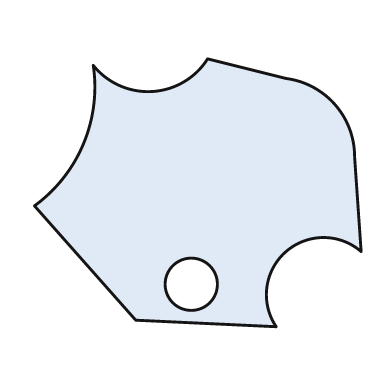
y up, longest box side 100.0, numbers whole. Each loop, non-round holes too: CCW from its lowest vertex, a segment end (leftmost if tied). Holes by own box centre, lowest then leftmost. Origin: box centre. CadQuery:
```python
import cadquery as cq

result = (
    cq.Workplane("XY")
    .moveTo(24.0, -41.0)
    .threePointArc((27.0, -18.0), (50.0, -18.0))
    .lineTo(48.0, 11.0)
    .threePointArc((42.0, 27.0), (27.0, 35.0))
    .lineTo(3.0, 41.0)
    .threePointArc((-14.0, 31.0), (-32.0, 39.0))
    .threePointArc((-35.0, 15.0), (-50.0, -4.0))
    .lineTo(-19.0, -39.0)
    .close()
    .moveTo(-2.0, -28.0)
    .circle(8.0)
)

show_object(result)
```